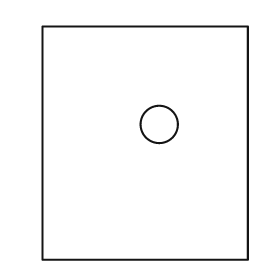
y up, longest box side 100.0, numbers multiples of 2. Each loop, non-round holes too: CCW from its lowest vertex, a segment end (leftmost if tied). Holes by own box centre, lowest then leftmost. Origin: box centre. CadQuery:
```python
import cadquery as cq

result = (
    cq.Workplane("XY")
    .moveTo(-44.0, -50.0)
    .lineTo(44.0, -50.0)
    .lineTo(44.0, 50.0)
    .lineTo(-44.0, 50.0)
    .close()
    .moveTo(6.0, 8.0)
    .circle(8.0)
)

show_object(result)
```